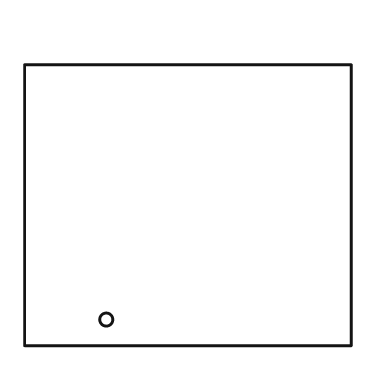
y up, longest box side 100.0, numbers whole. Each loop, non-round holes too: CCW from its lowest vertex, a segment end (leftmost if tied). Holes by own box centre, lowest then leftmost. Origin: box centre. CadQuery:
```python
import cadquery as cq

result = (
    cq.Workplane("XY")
    .moveTo(-50.0, -43.0)
    .lineTo(50.0, -43.0)
    .lineTo(50.0, 43.0)
    .lineTo(-50.0, 43.0)
    .close()
    .moveTo(-25.0, -35.0)
    .circle(2.0)
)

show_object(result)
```